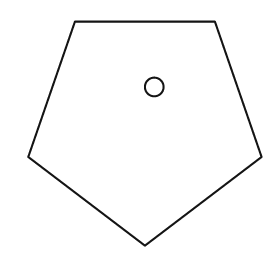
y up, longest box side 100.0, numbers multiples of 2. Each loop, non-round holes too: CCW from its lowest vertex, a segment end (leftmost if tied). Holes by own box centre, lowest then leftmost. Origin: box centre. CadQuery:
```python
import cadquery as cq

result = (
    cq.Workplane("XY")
    .moveTo(0.0, -48.0)
    .lineTo(50.0, -10.0)
    .lineTo(30.0, 48.0)
    .lineTo(-30.0, 48.0)
    .lineTo(-50.0, -10.0)
    .close()
    .moveTo(4.0, 20.0)
    .circle(4.0)
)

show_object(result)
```